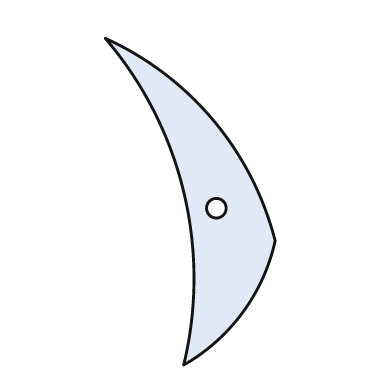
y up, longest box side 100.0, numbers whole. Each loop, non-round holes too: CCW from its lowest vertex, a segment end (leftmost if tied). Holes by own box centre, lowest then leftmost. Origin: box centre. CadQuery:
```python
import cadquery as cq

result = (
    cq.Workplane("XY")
    .moveTo(-2.0, -50.0)
    .threePointArc((16.0, -34.0), (26.0, -12.0))
    .threePointArc((7.0, 25.0), (-26.0, 50.0))
    .threePointArc((-2.0, 3.0), (-2.0, -50.0))
    .close()
    .moveTo(8.0, -2.0)
    .circle(3.0)
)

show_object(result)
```